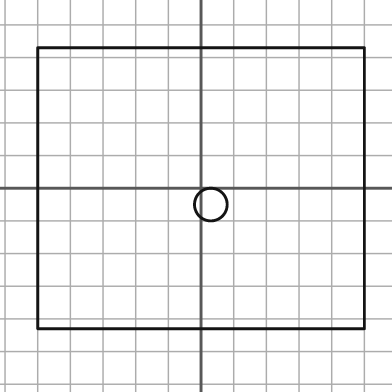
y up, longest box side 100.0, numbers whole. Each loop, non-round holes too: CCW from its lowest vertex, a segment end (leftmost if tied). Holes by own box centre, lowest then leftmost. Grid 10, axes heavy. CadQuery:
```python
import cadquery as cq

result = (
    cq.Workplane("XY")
    .moveTo(-50.0, -43.0)
    .lineTo(50.0, -43.0)
    .lineTo(50.0, 43.0)
    .lineTo(-50.0, 43.0)
    .close()
    .moveTo(3.0, -5.0)
    .circle(5.0)
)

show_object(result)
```